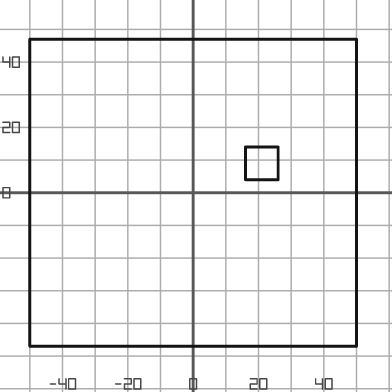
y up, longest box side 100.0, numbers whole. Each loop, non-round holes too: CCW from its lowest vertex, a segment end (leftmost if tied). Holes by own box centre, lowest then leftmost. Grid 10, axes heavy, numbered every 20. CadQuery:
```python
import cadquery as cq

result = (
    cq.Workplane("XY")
    .moveTo(-50.0, -47.0)
    .lineTo(50.0, -47.0)
    .lineTo(50.0, 47.0)
    .lineTo(-50.0, 47.0)
    .close()
    .moveTo(16.0, 4.0)
    .lineTo(26.0, 4.0)
    .lineTo(26.0, 14.0)
    .lineTo(16.0, 14.0)
    .close()
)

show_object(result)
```